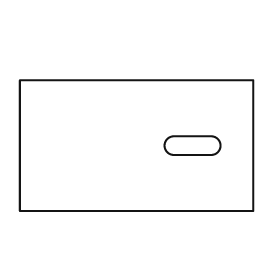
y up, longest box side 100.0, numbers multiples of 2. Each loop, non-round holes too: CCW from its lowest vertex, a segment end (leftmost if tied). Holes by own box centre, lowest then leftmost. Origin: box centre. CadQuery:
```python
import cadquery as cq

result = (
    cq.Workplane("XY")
    .moveTo(-50.0, -28.0)
    .lineTo(50.0, -28.0)
    .lineTo(50.0, 28.0)
    .lineTo(-50.0, 28.0)
    .close()
    .moveTo(16.0, -4.0)
    .lineTo(32.0, -4.0)
    .threePointArc((36.0, 0.0), (32.0, 4.0))
    .lineTo(16.0, 4.0)
    .threePointArc((12.0, 0.0), (16.0, -4.0))
    .close()
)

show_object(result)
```